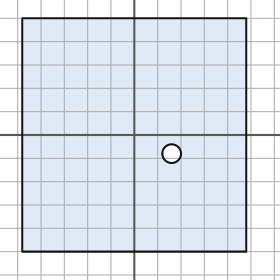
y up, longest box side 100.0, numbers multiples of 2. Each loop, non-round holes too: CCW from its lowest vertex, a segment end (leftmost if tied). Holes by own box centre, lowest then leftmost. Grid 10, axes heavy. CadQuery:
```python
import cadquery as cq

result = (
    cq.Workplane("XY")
    .moveTo(-48.0, -50.0)
    .lineTo(48.0, -50.0)
    .lineTo(48.0, 50.0)
    .lineTo(-48.0, 50.0)
    .close()
    .moveTo(16.0, -8.0)
    .circle(4.0)
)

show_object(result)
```